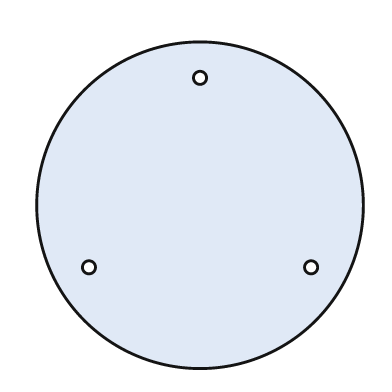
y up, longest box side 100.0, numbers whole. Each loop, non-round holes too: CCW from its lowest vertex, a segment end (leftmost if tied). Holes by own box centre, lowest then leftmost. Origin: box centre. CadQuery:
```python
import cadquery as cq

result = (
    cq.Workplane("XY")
    .moveTo(0.0, 0.0)
    .circle(50.0)
    .moveTo(-34.0, -19.0)
    .circle(2.0)
    .moveTo(34.0, -19.0)
    .circle(2.0)
    .moveTo(0.0, 39.0)
    .circle(2.0)
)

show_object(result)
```